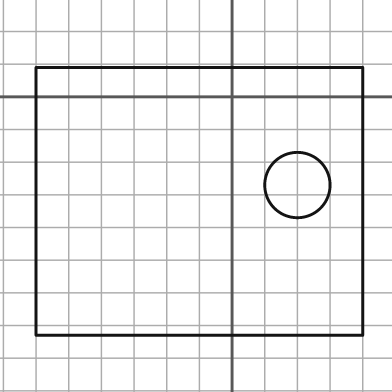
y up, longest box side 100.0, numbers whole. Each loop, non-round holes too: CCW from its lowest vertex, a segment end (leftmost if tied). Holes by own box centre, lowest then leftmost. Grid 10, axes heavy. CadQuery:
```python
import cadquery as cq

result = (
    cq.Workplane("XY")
    .moveTo(-60.0, -73.0)
    .lineTo(40.0, -73.0)
    .lineTo(40.0, 9.0)
    .lineTo(-60.0, 9.0)
    .close()
    .moveTo(20.0, -27.0)
    .circle(10.0)
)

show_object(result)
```